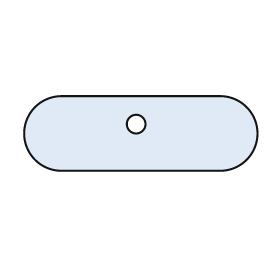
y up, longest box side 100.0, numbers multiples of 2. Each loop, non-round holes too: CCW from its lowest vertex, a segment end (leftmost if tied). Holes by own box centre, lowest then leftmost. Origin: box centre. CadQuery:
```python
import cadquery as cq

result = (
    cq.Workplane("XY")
    .moveTo(-34.0, -16.0)
    .lineTo(34.0, -16.0)
    .threePointArc((50.0, 0.0), (34.0, 16.0))
    .lineTo(-34.0, 16.0)
    .threePointArc((-50.0, 0.0), (-34.0, -16.0))
    .close()
    .moveTo(-2.0, 4.0)
    .circle(4.0)
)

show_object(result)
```